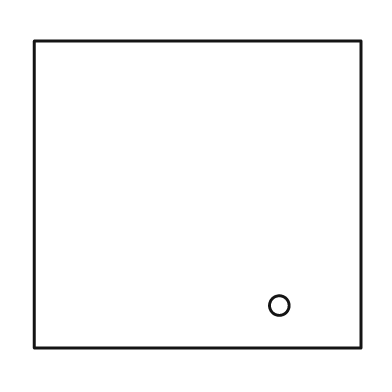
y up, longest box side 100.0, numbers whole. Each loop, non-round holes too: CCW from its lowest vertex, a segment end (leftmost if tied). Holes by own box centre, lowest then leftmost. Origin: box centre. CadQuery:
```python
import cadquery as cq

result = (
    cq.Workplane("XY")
    .moveTo(-50.0, -47.0)
    .lineTo(50.0, -47.0)
    .lineTo(50.0, 47.0)
    .lineTo(-50.0, 47.0)
    .close()
    .moveTo(25.0, -34.0)
    .circle(3.0)
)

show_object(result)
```